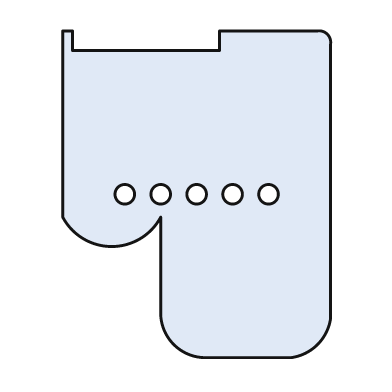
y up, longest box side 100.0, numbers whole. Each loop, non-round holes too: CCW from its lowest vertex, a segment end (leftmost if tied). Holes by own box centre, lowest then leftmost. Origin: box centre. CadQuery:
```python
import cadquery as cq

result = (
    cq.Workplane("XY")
    .moveTo(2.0, -50.0)
    .lineTo(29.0, -50.0)
    .threePointArc((37.0, -46.0), (41.0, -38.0))
    .lineTo(41.0, 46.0)
    .threePointArc((40.0, 49.0), (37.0, 50.0))
    .lineTo(7.0, 50.0)
    .lineTo(7.0, 44.0)
    .lineTo(-38.0, 44.0)
    .lineTo(-38.0, 50.0)
    .lineTo(-41.0, 50.0)
    .lineTo(-41.0, -7.0)
    .threePointArc((-26.0, -16.0), (-11.0, -7.0))
    .lineTo(-11.0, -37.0)
    .threePointArc((-7.0, -46.0), (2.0, -50.0))
    .close()
    .moveTo(-22.0, 0.0)
    .circle(3.0)
    .moveTo(-11.0, 0.0)
    .circle(3.0)
    .moveTo(0.0, 0.0)
    .circle(3.0)
    .moveTo(11.0, 0.0)
    .circle(3.0)
    .moveTo(22.0, 0.0)
    .circle(3.0)
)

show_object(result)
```